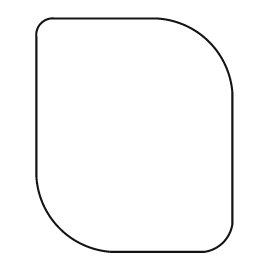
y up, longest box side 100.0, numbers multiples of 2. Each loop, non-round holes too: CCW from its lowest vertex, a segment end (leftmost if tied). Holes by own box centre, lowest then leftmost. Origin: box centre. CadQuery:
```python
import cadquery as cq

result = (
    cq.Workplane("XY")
    .moveTo(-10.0, -50.0)
    .lineTo(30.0, -50.0)
    .threePointArc((38.0, -46.0), (42.0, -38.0))
    .lineTo(42.0, 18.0)
    .threePointArc((32.0, 40.0), (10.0, 50.0))
    .lineTo(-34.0, 50.0)
    .threePointArc((-40.0, 48.0), (-42.0, 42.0))
    .lineTo(-42.0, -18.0)
    .threePointArc((-32.0, -40.0), (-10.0, -50.0))
    .close()
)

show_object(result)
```